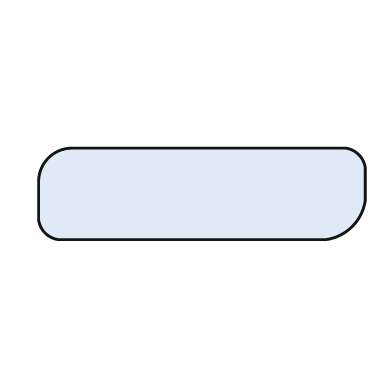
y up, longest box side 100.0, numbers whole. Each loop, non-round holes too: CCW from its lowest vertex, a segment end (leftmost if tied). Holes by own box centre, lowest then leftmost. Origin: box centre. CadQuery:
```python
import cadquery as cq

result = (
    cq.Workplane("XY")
    .moveTo(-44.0, -14.0)
    .lineTo(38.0, -14.0)
    .threePointArc((46.0, -10.0), (50.0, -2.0))
    .lineTo(50.0, 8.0)
    .threePointArc((48.0, 12.0), (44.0, 14.0))
    .lineTo(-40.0, 14.0)
    .threePointArc((-47.0, 11.0), (-50.0, 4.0))
    .lineTo(-50.0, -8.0)
    .threePointArc((-48.0, -12.0), (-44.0, -14.0))
    .close()
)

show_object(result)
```